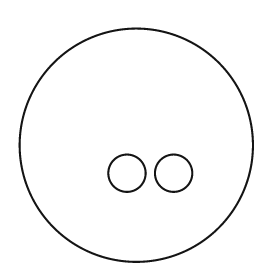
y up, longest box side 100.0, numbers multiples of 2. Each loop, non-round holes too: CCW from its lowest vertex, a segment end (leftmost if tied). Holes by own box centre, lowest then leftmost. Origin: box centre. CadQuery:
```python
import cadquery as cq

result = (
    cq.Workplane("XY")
    .moveTo(0.0, 0.0)
    .circle(50.0)
    .moveTo(-4.0, -12.0)
    .circle(8.0)
    .moveTo(16.0, -12.0)
    .circle(8.0)
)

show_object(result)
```